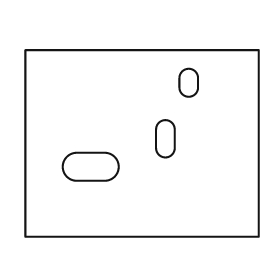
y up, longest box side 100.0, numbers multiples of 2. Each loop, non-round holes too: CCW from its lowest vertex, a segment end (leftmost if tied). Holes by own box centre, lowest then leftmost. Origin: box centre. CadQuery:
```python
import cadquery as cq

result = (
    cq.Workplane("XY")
    .moveTo(-50.0, -40.0)
    .lineTo(50.0, -40.0)
    .lineTo(50.0, 40.0)
    .lineTo(-50.0, 40.0)
    .close()
    .moveTo(-28.0, -16.0)
    .lineTo(-16.0, -16.0)
    .threePointArc((-10.0, -10.0), (-16.0, -4.0))
    .lineTo(-28.0, -4.0)
    .threePointArc((-34.0, -10.0), (-28.0, -16.0))
    .close()
    .moveTo(6.0, -2.0)
    .threePointArc((10.0, -6.0), (14.0, -2.0))
    .lineTo(14.0, 6.0)
    .threePointArc((10.0, 10.0), (6.0, 6.0))
    .close()
    .moveTo(16.0, 24.0)
    .threePointArc((20.0, 20.0), (24.0, 24.0))
    .lineTo(24.0, 28.0)
    .threePointArc((20.0, 32.0), (16.0, 28.0))
    .close()
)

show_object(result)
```